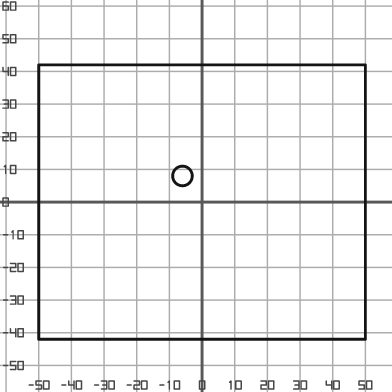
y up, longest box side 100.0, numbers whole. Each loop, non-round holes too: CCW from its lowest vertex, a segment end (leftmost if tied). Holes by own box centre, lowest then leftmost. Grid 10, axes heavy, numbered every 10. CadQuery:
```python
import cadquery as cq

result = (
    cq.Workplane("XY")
    .moveTo(-50.0, -42.0)
    .lineTo(50.0, -42.0)
    .lineTo(50.0, 42.0)
    .lineTo(-50.0, 42.0)
    .close()
    .moveTo(-6.0, 8.0)
    .circle(3.0)
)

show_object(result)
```